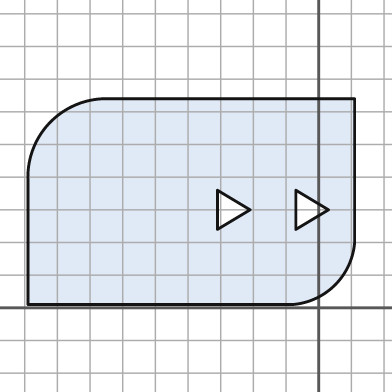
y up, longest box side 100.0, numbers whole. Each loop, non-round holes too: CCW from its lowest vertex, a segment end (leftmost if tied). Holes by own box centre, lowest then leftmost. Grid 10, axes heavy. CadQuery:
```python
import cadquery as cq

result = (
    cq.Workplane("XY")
    .moveTo(-89.0, 1.0)
    .lineTo(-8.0, 1.0)
    .threePointArc((5.0, 7.0), (11.0, 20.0))
    .lineTo(11.0, 64.0)
    .lineTo(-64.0, 64.0)
    .threePointArc((-82.0, 57.0), (-89.0, 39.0))
    .close()
    .moveTo(-31.0, 24.0)
    .lineTo(-21.0, 30.0)
    .lineTo(-31.0, 36.0)
    .close()
    .moveTo(-7.0, 24.0)
    .lineTo(3.0, 30.0)
    .lineTo(-7.0, 36.0)
    .close()
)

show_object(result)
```